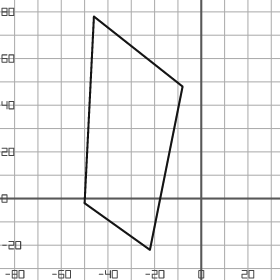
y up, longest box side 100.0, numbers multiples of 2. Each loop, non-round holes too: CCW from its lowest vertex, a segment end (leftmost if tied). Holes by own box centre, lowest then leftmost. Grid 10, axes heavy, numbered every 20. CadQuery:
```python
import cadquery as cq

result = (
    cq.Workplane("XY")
    .moveTo(-22.0, -22.0)
    .lineTo(-8.0, 48.0)
    .lineTo(-46.0, 78.0)
    .lineTo(-50.0, -2.0)
    .close()
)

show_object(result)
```